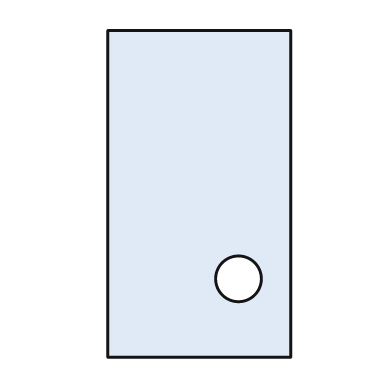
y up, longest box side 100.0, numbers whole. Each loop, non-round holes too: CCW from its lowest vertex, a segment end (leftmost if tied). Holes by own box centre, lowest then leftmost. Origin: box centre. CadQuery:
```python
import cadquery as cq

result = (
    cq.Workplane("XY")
    .moveTo(-28.0, -50.0)
    .lineTo(28.0, -50.0)
    .lineTo(28.0, 50.0)
    .lineTo(-28.0, 50.0)
    .close()
    .moveTo(12.0, -26.0)
    .circle(7.0)
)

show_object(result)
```